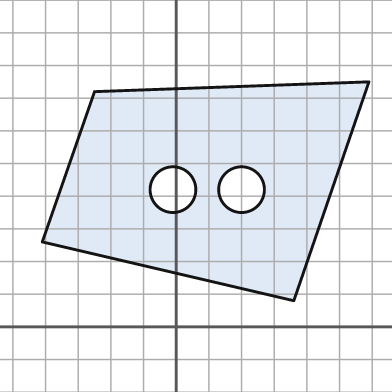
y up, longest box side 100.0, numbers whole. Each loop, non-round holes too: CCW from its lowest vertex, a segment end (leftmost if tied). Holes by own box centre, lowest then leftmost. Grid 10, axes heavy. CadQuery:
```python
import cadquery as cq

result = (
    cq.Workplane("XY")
    .moveTo(36.0, 8.0)
    .lineTo(59.0, 75.0)
    .lineTo(-25.0, 72.0)
    .lineTo(-41.0, 26.0)
    .close()
    .moveTo(-1.0, 42.0)
    .circle(7.0)
    .moveTo(20.0, 42.0)
    .circle(7.0)
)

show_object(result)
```